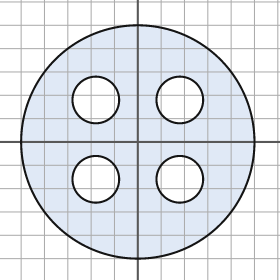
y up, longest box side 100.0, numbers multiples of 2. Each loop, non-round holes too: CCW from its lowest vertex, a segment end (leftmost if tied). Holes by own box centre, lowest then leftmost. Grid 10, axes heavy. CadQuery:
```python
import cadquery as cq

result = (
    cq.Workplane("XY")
    .moveTo(0.0, 0.0)
    .circle(50.0)
    .moveTo(-18.0, -16.0)
    .circle(10.0)
    .moveTo(18.0, -16.0)
    .circle(10.0)
    .moveTo(-18.0, 18.0)
    .circle(10.0)
    .moveTo(18.0, 18.0)
    .circle(10.0)
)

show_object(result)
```